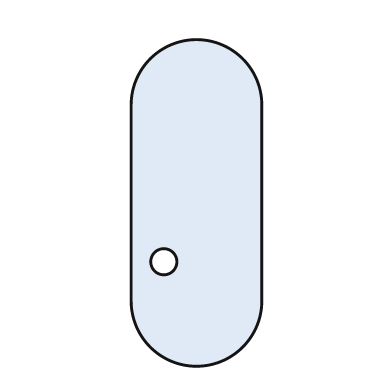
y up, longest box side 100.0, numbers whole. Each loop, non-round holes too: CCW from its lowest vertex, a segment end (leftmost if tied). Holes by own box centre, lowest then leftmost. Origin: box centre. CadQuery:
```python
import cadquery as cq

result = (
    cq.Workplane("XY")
    .moveTo(-20.0, -30.0)
    .threePointArc((0.0, -50.0), (20.0, -30.0))
    .lineTo(20.0, 30.0)
    .threePointArc((0.0, 50.0), (-20.0, 30.0))
    .close()
    .moveTo(-10.0, -18.0)
    .circle(4.0)
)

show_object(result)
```